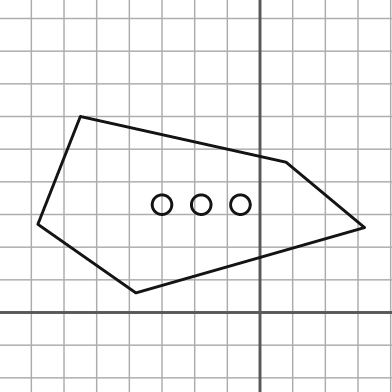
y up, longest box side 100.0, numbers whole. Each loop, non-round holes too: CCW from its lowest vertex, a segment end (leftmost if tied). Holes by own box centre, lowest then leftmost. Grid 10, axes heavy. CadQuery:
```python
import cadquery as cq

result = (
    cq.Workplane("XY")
    .moveTo(-38.0, 6.0)
    .lineTo(32.0, 26.0)
    .lineTo(8.0, 46.0)
    .lineTo(-55.0, 60.0)
    .lineTo(-68.0, 27.0)
    .close()
    .moveTo(-30.0, 33.0)
    .circle(3.0)
    .moveTo(-18.0, 33.0)
    .circle(3.0)
    .moveTo(-6.0, 33.0)
    .circle(3.0)
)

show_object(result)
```